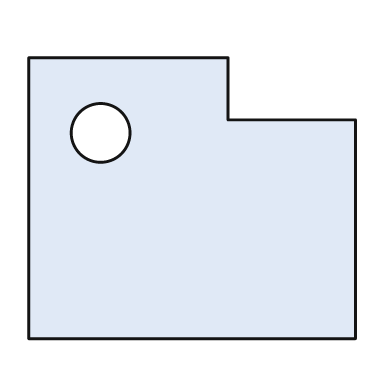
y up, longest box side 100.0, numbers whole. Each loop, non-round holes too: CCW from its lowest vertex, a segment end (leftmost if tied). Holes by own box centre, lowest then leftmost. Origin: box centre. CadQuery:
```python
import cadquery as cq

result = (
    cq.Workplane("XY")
    .moveTo(-50.0, -43.0)
    .lineTo(50.0, -43.0)
    .lineTo(50.0, 24.0)
    .lineTo(11.0, 24.0)
    .lineTo(11.0, 43.0)
    .lineTo(-50.0, 43.0)
    .close()
    .moveTo(-28.0, 20.0)
    .circle(9.0)
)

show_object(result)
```